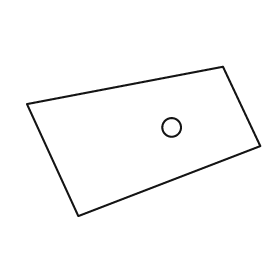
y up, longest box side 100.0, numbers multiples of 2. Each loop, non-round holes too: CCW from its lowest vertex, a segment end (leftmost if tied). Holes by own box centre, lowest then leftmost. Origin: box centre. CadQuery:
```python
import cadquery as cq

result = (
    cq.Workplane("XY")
    .moveTo(-28.0, -32.0)
    .lineTo(50.0, -2.0)
    .lineTo(34.0, 32.0)
    .lineTo(-50.0, 16.0)
    .close()
    .moveTo(12.0, 6.0)
    .circle(4.0)
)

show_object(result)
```